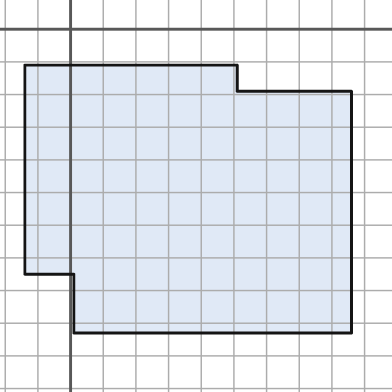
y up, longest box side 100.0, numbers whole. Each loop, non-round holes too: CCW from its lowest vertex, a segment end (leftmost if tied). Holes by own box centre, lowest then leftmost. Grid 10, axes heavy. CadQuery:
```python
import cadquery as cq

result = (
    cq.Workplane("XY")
    .moveTo(1.0, -93.0)
    .lineTo(86.0, -93.0)
    .lineTo(86.0, -19.0)
    .lineTo(51.0, -19.0)
    .lineTo(51.0, -11.0)
    .lineTo(-14.0, -11.0)
    .lineTo(-14.0, -75.0)
    .lineTo(1.0, -75.0)
    .close()
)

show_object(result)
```